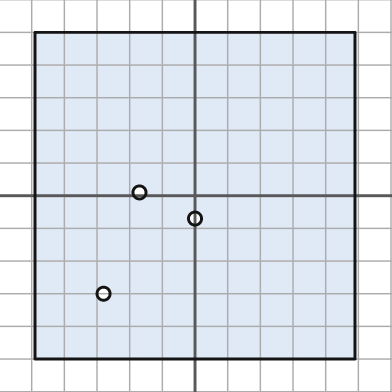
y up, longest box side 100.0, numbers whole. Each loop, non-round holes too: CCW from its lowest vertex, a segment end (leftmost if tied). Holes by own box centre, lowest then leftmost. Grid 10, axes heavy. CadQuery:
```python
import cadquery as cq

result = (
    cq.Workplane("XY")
    .moveTo(-49.0, -50.0)
    .lineTo(49.0, -50.0)
    .lineTo(49.0, 50.0)
    .lineTo(-49.0, 50.0)
    .close()
    .moveTo(-28.0, -30.0)
    .circle(2.0)
    .moveTo(0.0, -7.0)
    .circle(2.0)
    .moveTo(-17.0, 1.0)
    .circle(2.0)
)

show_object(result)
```